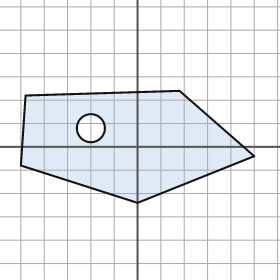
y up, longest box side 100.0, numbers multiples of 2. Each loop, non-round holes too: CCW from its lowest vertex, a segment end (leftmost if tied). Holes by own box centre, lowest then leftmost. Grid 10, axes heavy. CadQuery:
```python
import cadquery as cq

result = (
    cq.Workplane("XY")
    .moveTo(0.0, -24.0)
    .lineTo(50.0, -4.0)
    .lineTo(18.0, 24.0)
    .lineTo(-48.0, 22.0)
    .lineTo(-50.0, -8.0)
    .close()
    .moveTo(-20.0, 8.0)
    .circle(6.0)
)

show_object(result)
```